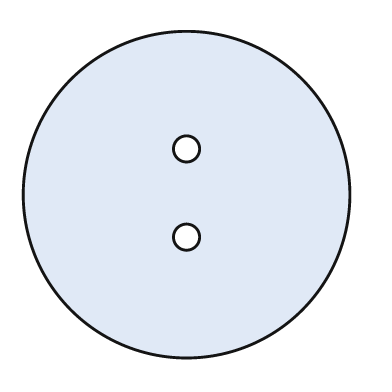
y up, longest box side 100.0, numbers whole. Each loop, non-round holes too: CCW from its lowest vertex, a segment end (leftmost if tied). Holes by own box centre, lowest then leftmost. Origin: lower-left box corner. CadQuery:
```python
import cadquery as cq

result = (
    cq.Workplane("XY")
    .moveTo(50.0, 50.0)
    .circle(50.0)
    .moveTo(50.0, 37.0)
    .circle(4.0)
    .moveTo(50.0, 64.0)
    .circle(4.0)
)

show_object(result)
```